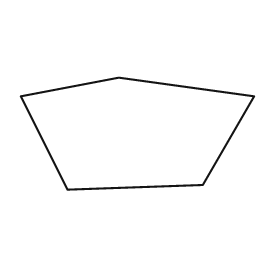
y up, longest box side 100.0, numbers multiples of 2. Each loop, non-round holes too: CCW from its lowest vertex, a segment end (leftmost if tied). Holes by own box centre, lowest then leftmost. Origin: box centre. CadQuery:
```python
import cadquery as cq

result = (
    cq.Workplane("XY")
    .moveTo(-30.0, -24.0)
    .lineTo(28.0, -22.0)
    .lineTo(50.0, 16.0)
    .lineTo(-8.0, 24.0)
    .lineTo(-50.0, 16.0)
    .close()
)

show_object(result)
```